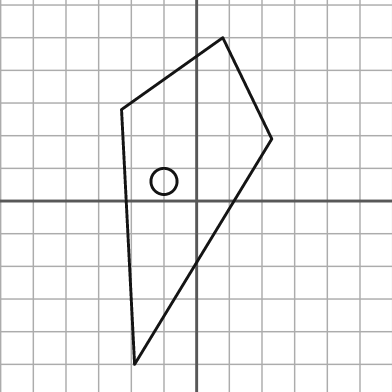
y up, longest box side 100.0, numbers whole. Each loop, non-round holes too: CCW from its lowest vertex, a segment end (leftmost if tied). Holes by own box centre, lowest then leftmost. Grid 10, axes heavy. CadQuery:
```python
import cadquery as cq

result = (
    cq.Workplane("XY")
    .moveTo(-19.0, -50.0)
    .lineTo(23.0, 19.0)
    .lineTo(8.0, 50.0)
    .lineTo(-23.0, 28.0)
    .close()
    .moveTo(-10.0, 6.0)
    .circle(4.0)
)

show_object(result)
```